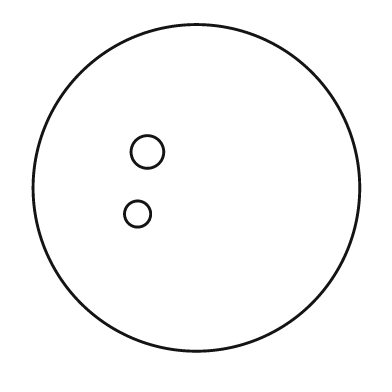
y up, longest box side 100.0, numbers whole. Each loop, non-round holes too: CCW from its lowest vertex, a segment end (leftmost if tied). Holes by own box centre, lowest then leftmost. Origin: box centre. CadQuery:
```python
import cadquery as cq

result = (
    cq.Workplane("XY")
    .moveTo(0.0, 0.0)
    .circle(50.0)
    .moveTo(-18.0, -8.0)
    .circle(4.0)
    .moveTo(-15.0, 11.0)
    .circle(5.0)
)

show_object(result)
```